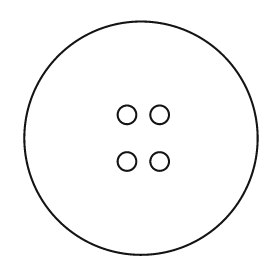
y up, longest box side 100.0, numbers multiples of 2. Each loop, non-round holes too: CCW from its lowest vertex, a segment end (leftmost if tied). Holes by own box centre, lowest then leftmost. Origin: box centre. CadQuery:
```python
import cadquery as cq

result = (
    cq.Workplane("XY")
    .moveTo(0.0, 0.0)
    .circle(50.0)
    .moveTo(-6.0, -10.0)
    .circle(4.0)
    .moveTo(8.0, -10.0)
    .circle(4.0)
    .moveTo(-6.0, 10.0)
    .circle(4.0)
    .moveTo(8.0, 10.0)
    .circle(4.0)
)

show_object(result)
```